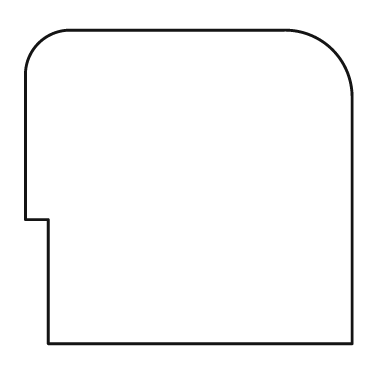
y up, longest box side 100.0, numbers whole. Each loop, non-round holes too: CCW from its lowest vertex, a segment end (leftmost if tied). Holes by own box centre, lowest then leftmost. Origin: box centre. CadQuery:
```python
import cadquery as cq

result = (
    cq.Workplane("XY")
    .moveTo(-43.0, -48.0)
    .lineTo(50.0, -48.0)
    .lineTo(50.0, 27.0)
    .threePointArc((44.0, 42.0), (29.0, 48.0))
    .lineTo(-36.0, 48.0)
    .threePointArc((-46.0, 44.0), (-50.0, 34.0))
    .lineTo(-50.0, -10.0)
    .lineTo(-43.0, -10.0)
    .close()
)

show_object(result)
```